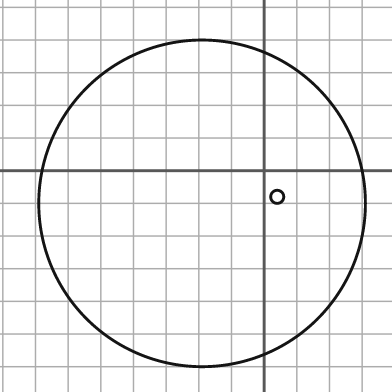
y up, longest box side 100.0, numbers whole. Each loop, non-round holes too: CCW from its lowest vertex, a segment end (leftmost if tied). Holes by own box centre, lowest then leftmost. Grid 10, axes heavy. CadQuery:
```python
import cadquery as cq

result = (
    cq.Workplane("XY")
    .moveTo(-19.0, -10.0)
    .circle(50.0)
    .moveTo(4.0, -8.0)
    .circle(2.0)
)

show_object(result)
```